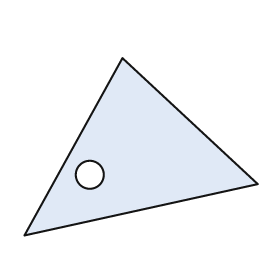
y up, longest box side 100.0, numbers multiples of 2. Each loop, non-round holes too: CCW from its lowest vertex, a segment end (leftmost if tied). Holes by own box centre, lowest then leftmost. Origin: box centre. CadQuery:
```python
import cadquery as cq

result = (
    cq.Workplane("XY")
    .moveTo(-50.0, -38.0)
    .lineTo(50.0, -16.0)
    .lineTo(-8.0, 38.0)
    .close()
    .moveTo(-22.0, -12.0)
    .circle(6.0)
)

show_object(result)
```